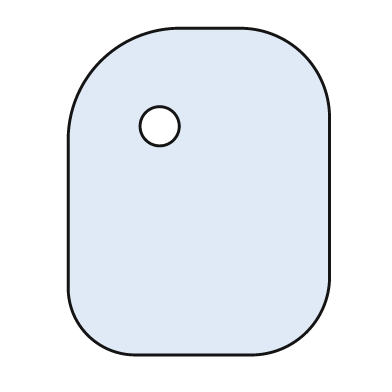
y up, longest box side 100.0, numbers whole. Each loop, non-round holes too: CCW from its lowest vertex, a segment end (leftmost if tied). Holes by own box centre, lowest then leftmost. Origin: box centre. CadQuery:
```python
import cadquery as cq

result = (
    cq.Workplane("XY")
    .moveTo(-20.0, -50.0)
    .lineTo(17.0, -50.0)
    .threePointArc((33.0, -43.0), (40.0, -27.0))
    .lineTo(40.0, 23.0)
    .threePointArc((32.0, 42.0), (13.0, 50.0))
    .lineTo(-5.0, 50.0)
    .threePointArc((-30.0, 40.0), (-40.0, 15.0))
    .lineTo(-40.0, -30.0)
    .threePointArc((-34.0, -44.0), (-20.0, -50.0))
    .close()
    .moveTo(-12.0, 20.0)
    .circle(6.0)
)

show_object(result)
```